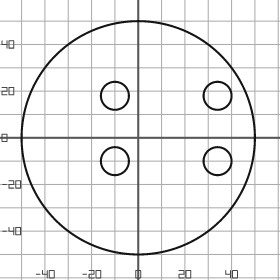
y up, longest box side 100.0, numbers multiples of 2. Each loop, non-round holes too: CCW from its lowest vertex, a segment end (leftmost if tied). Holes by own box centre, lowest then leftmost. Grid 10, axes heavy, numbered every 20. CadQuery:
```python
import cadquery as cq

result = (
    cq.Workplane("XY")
    .moveTo(0.0, 0.0)
    .circle(50.0)
    .moveTo(-10.0, -10.0)
    .circle(6.0)
    .moveTo(34.0, -10.0)
    .circle(6.0)
    .moveTo(-10.0, 18.0)
    .circle(6.0)
    .moveTo(34.0, 18.0)
    .circle(6.0)
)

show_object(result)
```